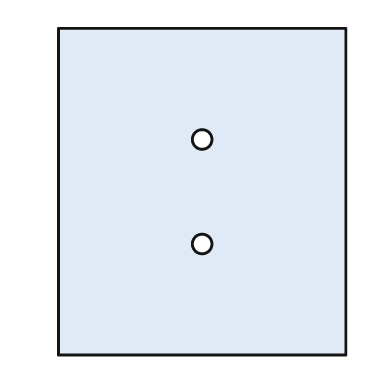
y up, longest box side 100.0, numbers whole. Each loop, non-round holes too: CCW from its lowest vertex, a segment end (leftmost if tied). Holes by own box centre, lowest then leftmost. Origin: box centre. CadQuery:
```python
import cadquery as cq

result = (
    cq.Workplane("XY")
    .moveTo(-44.0, -50.0)
    .lineTo(44.0, -50.0)
    .lineTo(44.0, 50.0)
    .lineTo(-44.0, 50.0)
    .close()
    .moveTo(0.0, -16.0)
    .circle(3.0)
    .moveTo(0.0, 16.0)
    .circle(3.0)
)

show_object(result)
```